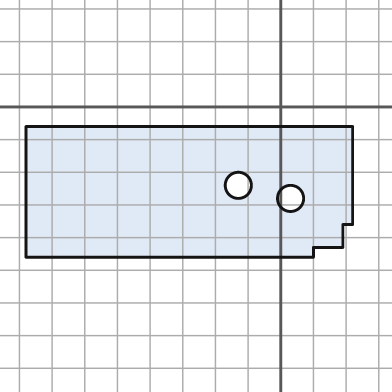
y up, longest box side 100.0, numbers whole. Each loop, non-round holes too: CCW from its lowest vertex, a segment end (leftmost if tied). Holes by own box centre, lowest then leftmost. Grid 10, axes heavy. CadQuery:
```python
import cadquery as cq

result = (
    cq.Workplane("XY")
    .moveTo(-78.0, -46.0)
    .lineTo(10.0, -46.0)
    .lineTo(10.0, -43.0)
    .lineTo(19.0, -43.0)
    .lineTo(19.0, -36.0)
    .lineTo(22.0, -36.0)
    .lineTo(22.0, -6.0)
    .lineTo(-78.0, -6.0)
    .close()
    .moveTo(3.0, -28.0)
    .circle(4.0)
    .moveTo(-13.0, -24.0)
    .circle(4.0)
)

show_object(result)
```